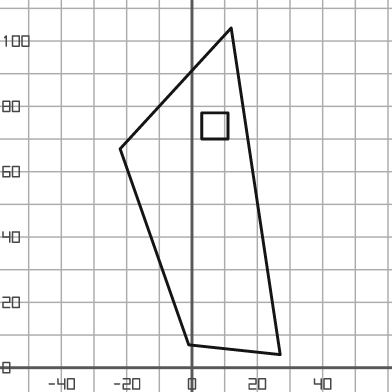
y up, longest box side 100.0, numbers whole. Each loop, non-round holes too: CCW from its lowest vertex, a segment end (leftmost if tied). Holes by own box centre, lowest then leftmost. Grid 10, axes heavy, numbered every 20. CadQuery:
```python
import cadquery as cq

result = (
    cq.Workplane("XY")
    .moveTo(27.0, 4.0)
    .lineTo(12.0, 104.0)
    .lineTo(-22.0, 67.0)
    .lineTo(-1.0, 7.0)
    .close()
    .moveTo(3.0, 70.0)
    .lineTo(11.0, 70.0)
    .lineTo(11.0, 78.0)
    .lineTo(3.0, 78.0)
    .close()
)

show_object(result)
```